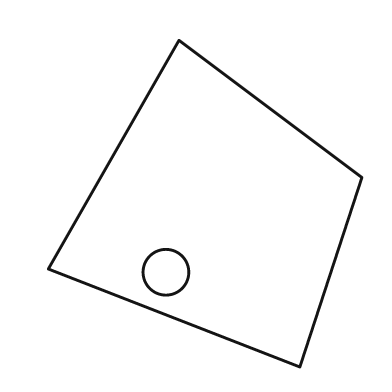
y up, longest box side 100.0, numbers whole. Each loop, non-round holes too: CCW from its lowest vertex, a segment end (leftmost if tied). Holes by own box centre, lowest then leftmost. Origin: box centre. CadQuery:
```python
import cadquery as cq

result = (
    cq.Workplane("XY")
    .moveTo(29.0, -50.0)
    .lineTo(48.0, 8.0)
    .lineTo(-8.0, 50.0)
    .lineTo(-48.0, -20.0)
    .close()
    .moveTo(-12.0, -21.0)
    .circle(7.0)
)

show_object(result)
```